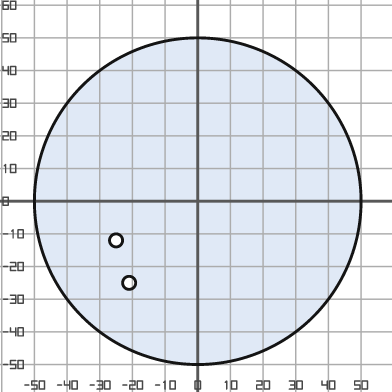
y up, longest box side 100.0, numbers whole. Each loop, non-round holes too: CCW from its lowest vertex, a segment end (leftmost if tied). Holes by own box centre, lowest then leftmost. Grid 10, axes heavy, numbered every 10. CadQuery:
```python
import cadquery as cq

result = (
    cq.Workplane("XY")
    .moveTo(0.0, 0.0)
    .circle(50.0)
    .moveTo(-21.0, -25.0)
    .circle(2.0)
    .moveTo(-25.0, -12.0)
    .circle(2.0)
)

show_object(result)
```